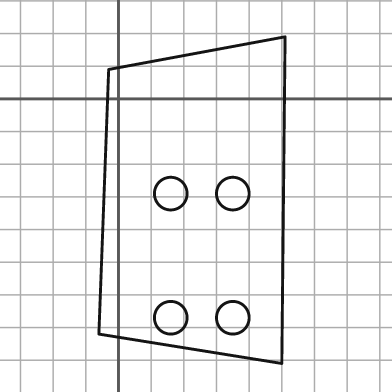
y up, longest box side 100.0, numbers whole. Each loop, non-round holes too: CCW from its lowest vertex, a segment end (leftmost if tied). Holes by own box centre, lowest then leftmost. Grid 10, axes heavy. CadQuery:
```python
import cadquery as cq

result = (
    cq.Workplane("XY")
    .moveTo(50.0, -81.0)
    .lineTo(51.0, 19.0)
    .lineTo(-3.0, 9.0)
    .lineTo(-6.0, -72.0)
    .close()
    .moveTo(16.0, -67.0)
    .circle(5.0)
    .moveTo(35.0, -67.0)
    .circle(5.0)
    .moveTo(16.0, -29.0)
    .circle(5.0)
    .moveTo(35.0, -29.0)
    .circle(5.0)
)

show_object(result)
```